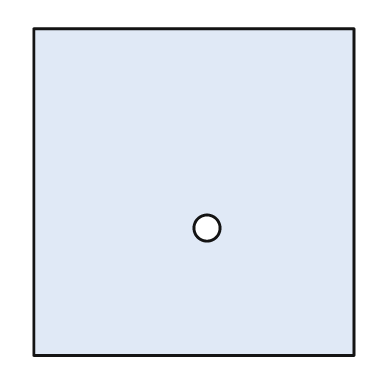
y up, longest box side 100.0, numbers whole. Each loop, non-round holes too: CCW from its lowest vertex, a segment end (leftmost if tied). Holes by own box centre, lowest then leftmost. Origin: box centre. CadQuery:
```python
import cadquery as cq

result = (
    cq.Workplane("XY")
    .moveTo(-49.0, -50.0)
    .lineTo(49.0, -50.0)
    .lineTo(49.0, 50.0)
    .lineTo(-49.0, 50.0)
    .close()
    .moveTo(4.0, -11.0)
    .circle(4.0)
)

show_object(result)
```